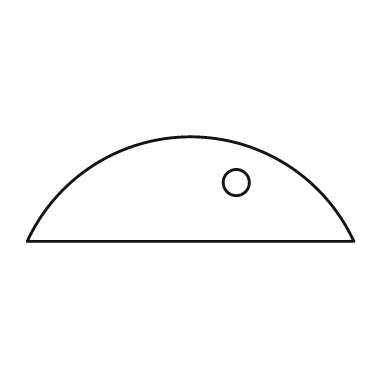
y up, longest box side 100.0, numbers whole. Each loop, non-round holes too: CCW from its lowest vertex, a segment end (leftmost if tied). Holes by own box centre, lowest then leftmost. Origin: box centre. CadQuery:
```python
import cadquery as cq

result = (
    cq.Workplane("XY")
    .moveTo(-50.0, -16.0)
    .lineTo(50.0, -16.0)
    .threePointArc((0.0, 16.0), (-50.0, -16.0))
    .close()
    .moveTo(14.0, 2.0)
    .circle(4.0)
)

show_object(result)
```